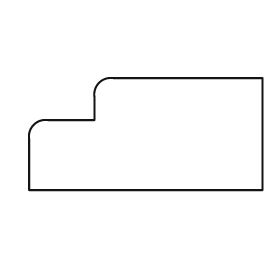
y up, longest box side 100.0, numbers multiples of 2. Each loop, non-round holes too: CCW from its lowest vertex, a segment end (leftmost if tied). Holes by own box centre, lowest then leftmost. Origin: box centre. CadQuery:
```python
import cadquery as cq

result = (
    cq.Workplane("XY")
    .moveTo(-50.0, -24.0)
    .lineTo(50.0, -24.0)
    .lineTo(50.0, 24.0)
    .lineTo(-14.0, 24.0)
    .threePointArc((-20.0, 22.0), (-22.0, 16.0))
    .lineTo(-22.0, 6.0)
    .lineTo(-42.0, 6.0)
    .threePointArc((-48.0, 4.0), (-50.0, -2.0))
    .close()
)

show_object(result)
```